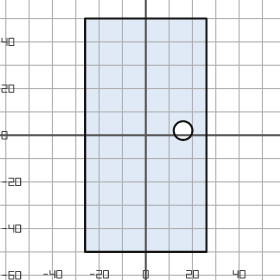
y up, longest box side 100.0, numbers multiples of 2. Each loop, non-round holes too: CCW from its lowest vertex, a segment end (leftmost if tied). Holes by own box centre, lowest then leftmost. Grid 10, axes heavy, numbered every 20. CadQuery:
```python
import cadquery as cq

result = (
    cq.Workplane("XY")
    .moveTo(-26.0, -50.0)
    .lineTo(26.0, -50.0)
    .lineTo(26.0, 50.0)
    .lineTo(-26.0, 50.0)
    .close()
    .moveTo(16.0, 2.0)
    .circle(4.0)
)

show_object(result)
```